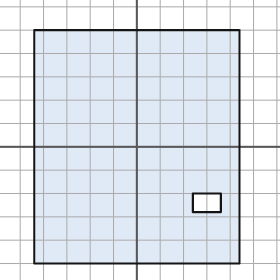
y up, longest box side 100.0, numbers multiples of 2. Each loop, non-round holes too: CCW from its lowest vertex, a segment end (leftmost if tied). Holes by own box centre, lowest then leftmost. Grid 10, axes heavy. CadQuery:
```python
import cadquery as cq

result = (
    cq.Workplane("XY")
    .moveTo(-44.0, -50.0)
    .lineTo(44.0, -50.0)
    .lineTo(44.0, 50.0)
    .lineTo(-44.0, 50.0)
    .close()
    .moveTo(24.0, -28.0)
    .lineTo(36.0, -28.0)
    .lineTo(36.0, -20.0)
    .lineTo(24.0, -20.0)
    .close()
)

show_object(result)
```